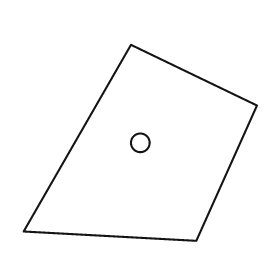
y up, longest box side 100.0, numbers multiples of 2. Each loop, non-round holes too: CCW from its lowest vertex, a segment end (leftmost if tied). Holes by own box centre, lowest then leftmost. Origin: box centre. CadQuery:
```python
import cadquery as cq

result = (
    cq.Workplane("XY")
    .moveTo(24.0, -42.0)
    .lineTo(50.0, 16.0)
    .lineTo(-4.0, 42.0)
    .lineTo(-50.0, -38.0)
    .close()
    .moveTo(0.0, 0.0)
    .circle(4.0)
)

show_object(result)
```